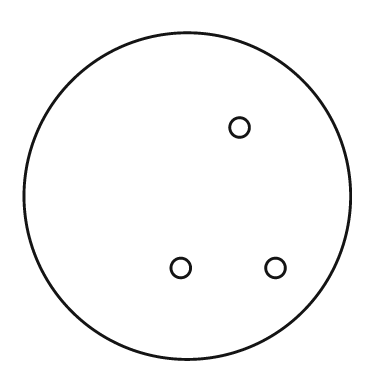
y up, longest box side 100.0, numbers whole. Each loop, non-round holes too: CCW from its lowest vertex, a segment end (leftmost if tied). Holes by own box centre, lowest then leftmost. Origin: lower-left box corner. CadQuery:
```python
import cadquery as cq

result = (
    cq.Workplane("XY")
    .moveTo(50.0, 50.0)
    .circle(50.0)
    .moveTo(48.0, 28.0)
    .circle(3.0)
    .moveTo(77.0, 28.0)
    .circle(3.0)
    .moveTo(66.0, 71.0)
    .circle(3.0)
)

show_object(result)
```